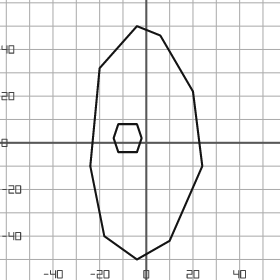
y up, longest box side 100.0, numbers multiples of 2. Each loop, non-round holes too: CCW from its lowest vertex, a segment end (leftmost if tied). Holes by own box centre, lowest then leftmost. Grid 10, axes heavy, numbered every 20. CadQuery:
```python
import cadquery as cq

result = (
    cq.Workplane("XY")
    .moveTo(-4.0, -50.0)
    .lineTo(10.0, -42.0)
    .lineTo(24.0, -10.0)
    .lineTo(20.0, 22.0)
    .lineTo(6.0, 46.0)
    .lineTo(-4.0, 50.0)
    .lineTo(-20.0, 32.0)
    .lineTo(-24.0, -10.0)
    .lineTo(-18.0, -40.0)
    .close()
    .moveTo(-12.0, -4.0)
    .lineTo(-4.0, -4.0)
    .lineTo(-2.0, 2.0)
    .lineTo(-4.0, 8.0)
    .lineTo(-12.0, 8.0)
    .lineTo(-14.0, 2.0)
    .close()
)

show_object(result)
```